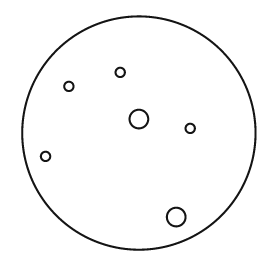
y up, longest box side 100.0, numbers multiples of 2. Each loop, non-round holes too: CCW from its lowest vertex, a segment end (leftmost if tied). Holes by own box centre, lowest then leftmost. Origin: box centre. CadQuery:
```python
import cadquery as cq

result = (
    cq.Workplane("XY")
    .moveTo(0.0, 0.0)
    .circle(50.0)
    .moveTo(16.0, -36.0)
    .circle(4.0)
    .moveTo(-40.0, -10.0)
    .circle(2.0)
    .moveTo(22.0, 2.0)
    .circle(2.0)
    .moveTo(0.0, 6.0)
    .circle(4.0)
    .moveTo(-30.0, 20.0)
    .circle(2.0)
    .moveTo(-8.0, 26.0)
    .circle(2.0)
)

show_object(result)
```